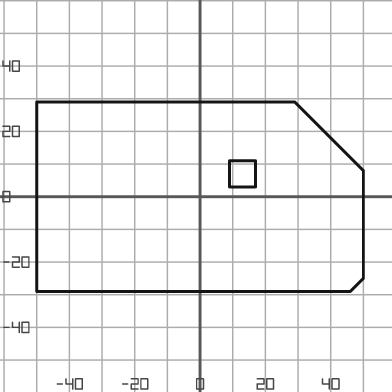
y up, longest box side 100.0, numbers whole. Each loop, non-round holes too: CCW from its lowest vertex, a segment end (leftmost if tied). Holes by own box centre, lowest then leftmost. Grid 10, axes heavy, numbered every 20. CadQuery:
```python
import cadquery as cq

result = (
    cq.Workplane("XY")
    .moveTo(-50.0, -29.0)
    .lineTo(46.0, -29.0)
    .lineTo(50.0, -25.0)
    .lineTo(50.0, 8.0)
    .lineTo(29.0, 29.0)
    .lineTo(-50.0, 29.0)
    .close()
    .moveTo(9.0, 3.0)
    .lineTo(17.0, 3.0)
    .lineTo(17.0, 11.0)
    .lineTo(9.0, 11.0)
    .close()
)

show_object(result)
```